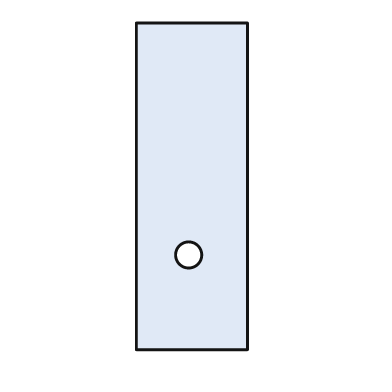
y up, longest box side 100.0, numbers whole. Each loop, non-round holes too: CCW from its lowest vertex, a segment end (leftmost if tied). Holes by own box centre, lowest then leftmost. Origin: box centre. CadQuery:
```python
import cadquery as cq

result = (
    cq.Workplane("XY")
    .moveTo(-17.0, -50.0)
    .lineTo(17.0, -50.0)
    .lineTo(17.0, 50.0)
    .lineTo(-17.0, 50.0)
    .close()
    .moveTo(-1.0, -21.0)
    .circle(4.0)
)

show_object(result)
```